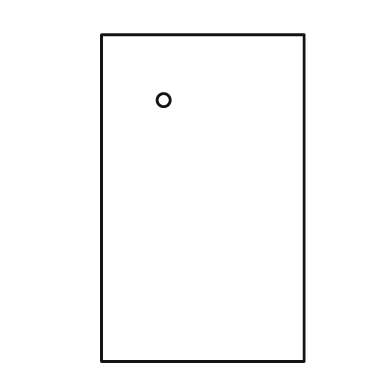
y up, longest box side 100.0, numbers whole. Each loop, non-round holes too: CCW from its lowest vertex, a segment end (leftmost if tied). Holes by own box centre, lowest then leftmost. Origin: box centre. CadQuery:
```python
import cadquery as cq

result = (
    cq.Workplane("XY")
    .moveTo(-31.0, -50.0)
    .lineTo(31.0, -50.0)
    .lineTo(31.0, 50.0)
    .lineTo(-31.0, 50.0)
    .close()
    .moveTo(-12.0, 30.0)
    .circle(2.0)
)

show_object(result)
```